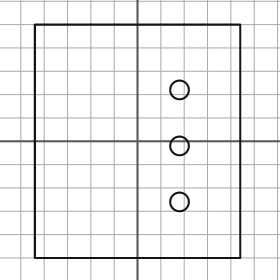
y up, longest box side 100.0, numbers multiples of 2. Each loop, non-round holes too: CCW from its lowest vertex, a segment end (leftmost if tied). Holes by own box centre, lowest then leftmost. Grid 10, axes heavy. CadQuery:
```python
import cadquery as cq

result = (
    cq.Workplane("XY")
    .moveTo(-44.0, -50.0)
    .lineTo(44.0, -50.0)
    .lineTo(44.0, 50.0)
    .lineTo(-44.0, 50.0)
    .close()
    .moveTo(18.0, -26.0)
    .circle(4.0)
    .moveTo(18.0, -2.0)
    .circle(4.0)
    .moveTo(18.0, 22.0)
    .circle(4.0)
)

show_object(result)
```